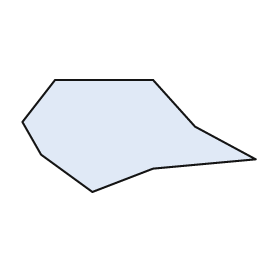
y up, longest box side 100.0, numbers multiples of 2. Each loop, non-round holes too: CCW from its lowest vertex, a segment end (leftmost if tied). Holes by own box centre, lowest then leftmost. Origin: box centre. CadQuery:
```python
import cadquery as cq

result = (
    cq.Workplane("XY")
    .moveTo(-20.0, -24.0)
    .lineTo(6.0, -14.0)
    .lineTo(50.0, -10.0)
    .lineTo(24.0, 4.0)
    .lineTo(6.0, 24.0)
    .lineTo(-36.0, 24.0)
    .lineTo(-50.0, 6.0)
    .lineTo(-42.0, -8.0)
    .close()
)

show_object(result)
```